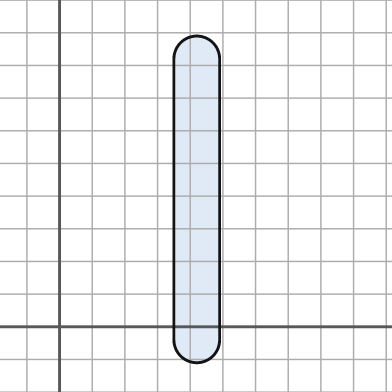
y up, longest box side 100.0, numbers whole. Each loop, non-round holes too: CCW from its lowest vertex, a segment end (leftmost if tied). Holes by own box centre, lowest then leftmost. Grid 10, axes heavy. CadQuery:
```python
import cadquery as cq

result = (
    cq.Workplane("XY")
    .moveTo(35.0, -4.0)
    .threePointArc((42.0, -11.0), (49.0, -4.0))
    .lineTo(49.0, 82.0)
    .threePointArc((42.0, 89.0), (35.0, 82.0))
    .close()
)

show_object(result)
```